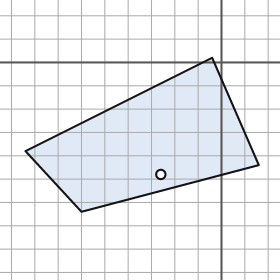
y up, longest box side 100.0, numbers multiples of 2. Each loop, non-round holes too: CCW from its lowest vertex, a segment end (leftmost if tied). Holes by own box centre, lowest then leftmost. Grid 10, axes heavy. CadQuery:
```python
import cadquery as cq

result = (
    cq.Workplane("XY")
    .moveTo(-60.0, -64.0)
    .lineTo(16.0, -44.0)
    .lineTo(-4.0, 2.0)
    .lineTo(-84.0, -38.0)
    .close()
    .moveTo(-26.0, -48.0)
    .circle(2.0)
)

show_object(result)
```